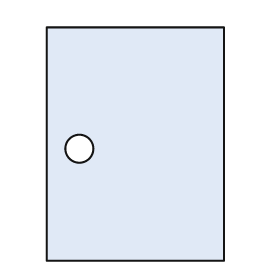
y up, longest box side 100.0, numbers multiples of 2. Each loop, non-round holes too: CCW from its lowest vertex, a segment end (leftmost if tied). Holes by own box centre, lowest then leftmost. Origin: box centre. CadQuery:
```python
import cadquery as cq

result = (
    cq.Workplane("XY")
    .moveTo(-38.0, -50.0)
    .lineTo(38.0, -50.0)
    .lineTo(38.0, 50.0)
    .lineTo(-38.0, 50.0)
    .close()
    .moveTo(-24.0, -2.0)
    .circle(6.0)
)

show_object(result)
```